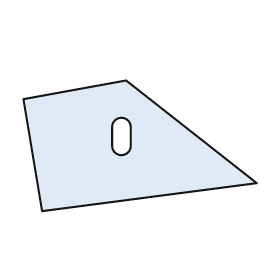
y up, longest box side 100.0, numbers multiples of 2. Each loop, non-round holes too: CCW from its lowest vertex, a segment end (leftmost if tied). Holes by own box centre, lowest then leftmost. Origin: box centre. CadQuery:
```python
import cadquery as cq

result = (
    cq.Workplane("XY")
    .moveTo(-42.0, -28.0)
    .lineTo(50.0, -16.0)
    .lineTo(-6.0, 28.0)
    .lineTo(-50.0, 20.0)
    .close()
    .moveTo(-12.0, 0.0)
    .threePointArc((-8.0, -4.0), (-4.0, 0.0))
    .lineTo(-4.0, 8.0)
    .threePointArc((-8.0, 12.0), (-12.0, 8.0))
    .close()
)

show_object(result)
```